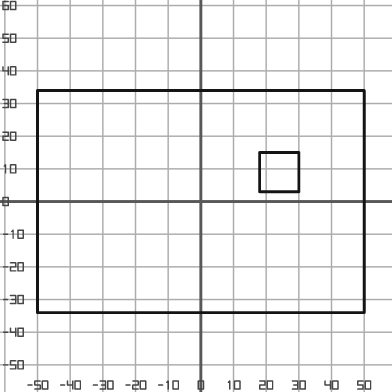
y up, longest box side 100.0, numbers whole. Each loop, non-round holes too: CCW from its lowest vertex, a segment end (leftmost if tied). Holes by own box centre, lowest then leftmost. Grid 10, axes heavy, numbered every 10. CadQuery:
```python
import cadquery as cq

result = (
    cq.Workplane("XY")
    .moveTo(-50.0, -34.0)
    .lineTo(50.0, -34.0)
    .lineTo(50.0, 34.0)
    .lineTo(-50.0, 34.0)
    .close()
    .moveTo(18.0, 3.0)
    .lineTo(30.0, 3.0)
    .lineTo(30.0, 15.0)
    .lineTo(18.0, 15.0)
    .close()
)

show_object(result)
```